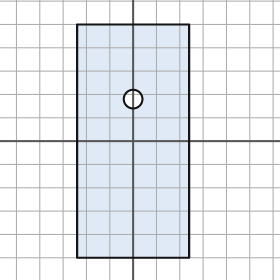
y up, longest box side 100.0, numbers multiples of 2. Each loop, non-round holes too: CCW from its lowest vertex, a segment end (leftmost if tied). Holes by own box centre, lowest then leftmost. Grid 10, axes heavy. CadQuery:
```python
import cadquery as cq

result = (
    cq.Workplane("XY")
    .moveTo(-24.0, -50.0)
    .lineTo(24.0, -50.0)
    .lineTo(24.0, 50.0)
    .lineTo(-24.0, 50.0)
    .close()
    .moveTo(0.0, 18.0)
    .circle(4.0)
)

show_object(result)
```